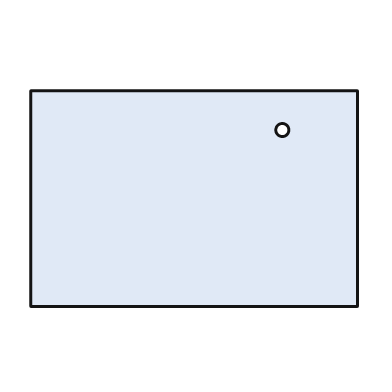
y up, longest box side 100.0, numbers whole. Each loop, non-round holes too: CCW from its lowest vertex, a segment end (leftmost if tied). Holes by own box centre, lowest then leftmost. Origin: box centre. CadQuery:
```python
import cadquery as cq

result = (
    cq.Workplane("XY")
    .moveTo(-50.0, -33.0)
    .lineTo(50.0, -33.0)
    .lineTo(50.0, 33.0)
    .lineTo(-50.0, 33.0)
    .close()
    .moveTo(27.0, 21.0)
    .circle(2.0)
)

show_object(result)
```